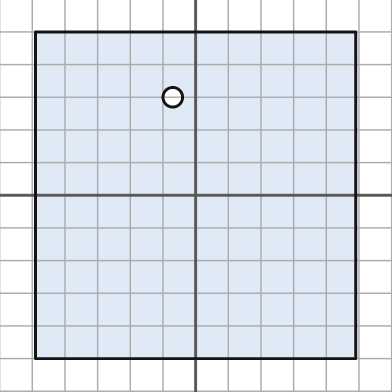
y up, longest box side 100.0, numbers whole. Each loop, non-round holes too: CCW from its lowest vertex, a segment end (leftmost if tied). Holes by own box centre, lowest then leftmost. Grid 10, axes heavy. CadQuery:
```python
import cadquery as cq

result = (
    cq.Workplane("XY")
    .moveTo(-49.0, -50.0)
    .lineTo(49.0, -50.0)
    .lineTo(49.0, 50.0)
    .lineTo(-49.0, 50.0)
    .close()
    .moveTo(-7.0, 30.0)
    .circle(3.0)
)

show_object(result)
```